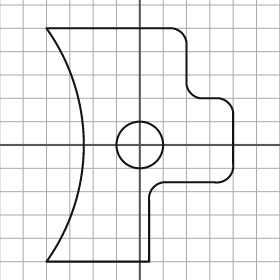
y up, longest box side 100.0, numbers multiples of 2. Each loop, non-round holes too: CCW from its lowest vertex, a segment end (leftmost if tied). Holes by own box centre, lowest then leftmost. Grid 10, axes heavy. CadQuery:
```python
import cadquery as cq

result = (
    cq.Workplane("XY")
    .moveTo(-40.0, -50.0)
    .lineTo(4.0, -50.0)
    .lineTo(4.0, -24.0)
    .threePointArc((6.0, -18.0), (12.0, -16.0))
    .lineTo(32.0, -16.0)
    .threePointArc((38.0, -14.0), (40.0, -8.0))
    .lineTo(40.0, 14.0)
    .threePointArc((38.0, 18.0), (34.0, 20.0))
    .lineTo(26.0, 20.0)
    .threePointArc((22.0, 22.0), (20.0, 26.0))
    .lineTo(20.0, 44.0)
    .threePointArc((18.0, 48.0), (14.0, 50.0))
    .lineTo(-40.0, 50.0)
    .threePointArc((-24.0, 0.0), (-40.0, -50.0))
    .close()
    .moveTo(0.0, 0.0)
    .circle(10.0)
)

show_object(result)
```